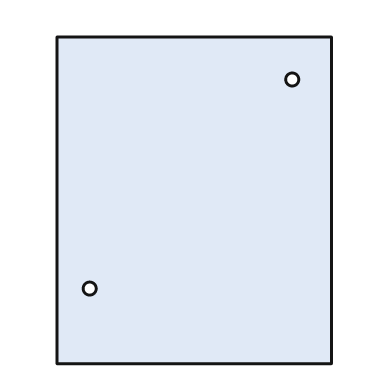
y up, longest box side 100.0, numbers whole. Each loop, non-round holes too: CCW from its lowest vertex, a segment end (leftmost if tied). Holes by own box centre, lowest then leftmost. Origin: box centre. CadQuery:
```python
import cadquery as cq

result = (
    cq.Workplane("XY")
    .moveTo(-42.0, -50.0)
    .lineTo(42.0, -50.0)
    .lineTo(42.0, 50.0)
    .lineTo(-42.0, 50.0)
    .close()
    .moveTo(-32.0, -27.0)
    .circle(2.0)
    .moveTo(30.0, 37.0)
    .circle(2.0)
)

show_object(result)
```